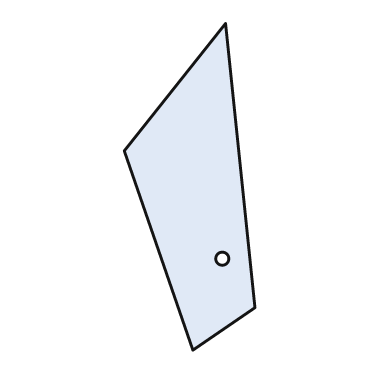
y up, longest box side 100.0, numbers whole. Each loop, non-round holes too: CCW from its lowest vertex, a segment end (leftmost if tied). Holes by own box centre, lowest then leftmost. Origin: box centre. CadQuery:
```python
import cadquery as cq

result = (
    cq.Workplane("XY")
    .moveTo(1.0, -50.0)
    .lineTo(20.0, -37.0)
    .lineTo(11.0, 50.0)
    .lineTo(-20.0, 11.0)
    .close()
    .moveTo(10.0, -22.0)
    .circle(2.0)
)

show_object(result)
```